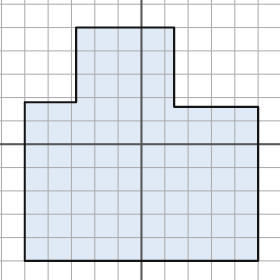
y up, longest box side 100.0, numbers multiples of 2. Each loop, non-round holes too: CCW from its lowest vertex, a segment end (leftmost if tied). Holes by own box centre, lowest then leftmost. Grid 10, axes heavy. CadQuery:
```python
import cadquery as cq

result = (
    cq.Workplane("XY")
    .moveTo(-50.0, -50.0)
    .lineTo(50.0, -50.0)
    .lineTo(50.0, 16.0)
    .lineTo(14.0, 16.0)
    .lineTo(14.0, 50.0)
    .lineTo(-28.0, 50.0)
    .lineTo(-28.0, 18.0)
    .lineTo(-50.0, 18.0)
    .close()
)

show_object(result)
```